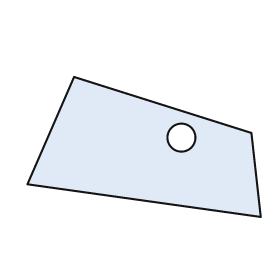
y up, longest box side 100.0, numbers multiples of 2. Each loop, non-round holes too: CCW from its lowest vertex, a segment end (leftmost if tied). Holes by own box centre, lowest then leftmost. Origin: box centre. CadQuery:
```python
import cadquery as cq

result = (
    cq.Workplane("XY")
    .moveTo(50.0, -30.0)
    .lineTo(46.0, 6.0)
    .lineTo(-30.0, 30.0)
    .lineTo(-50.0, -16.0)
    .close()
    .moveTo(16.0, 4.0)
    .circle(6.0)
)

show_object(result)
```